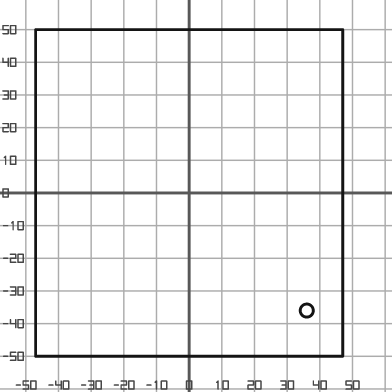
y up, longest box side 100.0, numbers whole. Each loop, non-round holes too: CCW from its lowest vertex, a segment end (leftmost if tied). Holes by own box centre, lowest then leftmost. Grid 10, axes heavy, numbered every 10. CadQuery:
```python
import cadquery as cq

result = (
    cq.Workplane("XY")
    .moveTo(-47.0, -50.0)
    .lineTo(47.0, -50.0)
    .lineTo(47.0, 50.0)
    .lineTo(-47.0, 50.0)
    .close()
    .moveTo(36.0, -36.0)
    .circle(2.0)
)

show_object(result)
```